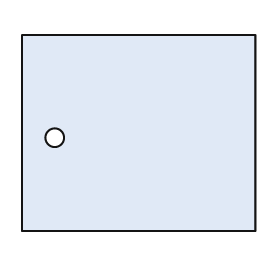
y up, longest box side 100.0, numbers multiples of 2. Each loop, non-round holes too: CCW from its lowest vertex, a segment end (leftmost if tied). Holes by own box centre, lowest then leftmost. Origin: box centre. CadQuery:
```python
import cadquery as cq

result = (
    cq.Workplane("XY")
    .moveTo(-50.0, -42.0)
    .lineTo(50.0, -42.0)
    .lineTo(50.0, 42.0)
    .lineTo(-50.0, 42.0)
    .close()
    .moveTo(-36.0, -2.0)
    .circle(4.0)
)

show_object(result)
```